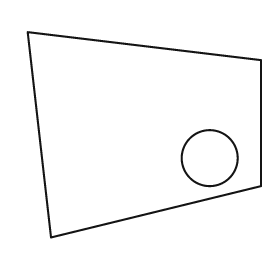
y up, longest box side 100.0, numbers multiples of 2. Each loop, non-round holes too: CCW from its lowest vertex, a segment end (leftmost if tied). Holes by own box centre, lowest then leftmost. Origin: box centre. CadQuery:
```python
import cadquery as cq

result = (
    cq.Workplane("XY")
    .moveTo(-40.0, -44.0)
    .lineTo(50.0, -22.0)
    .lineTo(50.0, 32.0)
    .lineTo(-50.0, 44.0)
    .close()
    .moveTo(28.0, -10.0)
    .circle(12.0)
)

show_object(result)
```